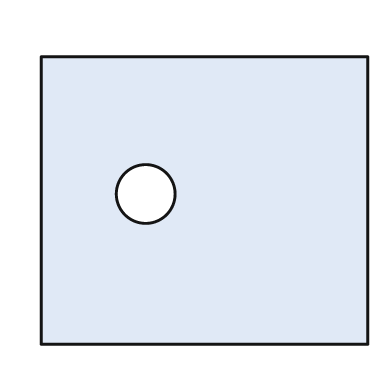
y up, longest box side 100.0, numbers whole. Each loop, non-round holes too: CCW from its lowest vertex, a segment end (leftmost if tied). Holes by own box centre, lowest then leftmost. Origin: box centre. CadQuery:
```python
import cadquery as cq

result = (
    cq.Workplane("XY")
    .moveTo(-50.0, -44.0)
    .lineTo(50.0, -44.0)
    .lineTo(50.0, 44.0)
    .lineTo(-50.0, 44.0)
    .close()
    .moveTo(-18.0, 2.0)
    .circle(9.0)
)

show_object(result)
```